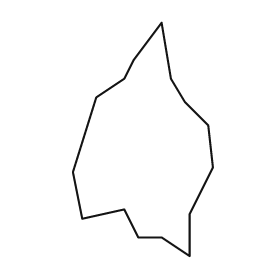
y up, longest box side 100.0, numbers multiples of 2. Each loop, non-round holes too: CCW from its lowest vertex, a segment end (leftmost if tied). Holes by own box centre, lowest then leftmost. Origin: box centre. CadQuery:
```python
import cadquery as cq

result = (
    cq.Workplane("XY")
    .moveTo(20.0, -50.0)
    .lineTo(20.0, -32.0)
    .lineTo(30.0, -12.0)
    .lineTo(28.0, 6.0)
    .lineTo(18.0, 16.0)
    .lineTo(12.0, 26.0)
    .lineTo(8.0, 50.0)
    .lineTo(-4.0, 34.0)
    .lineTo(-8.0, 26.0)
    .lineTo(-20.0, 18.0)
    .lineTo(-30.0, -14.0)
    .lineTo(-26.0, -34.0)
    .lineTo(-8.0, -30.0)
    .lineTo(-2.0, -42.0)
    .lineTo(8.0, -42.0)
    .close()
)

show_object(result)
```